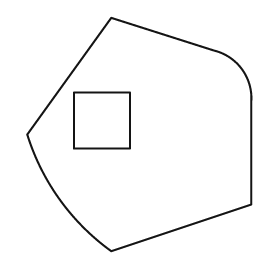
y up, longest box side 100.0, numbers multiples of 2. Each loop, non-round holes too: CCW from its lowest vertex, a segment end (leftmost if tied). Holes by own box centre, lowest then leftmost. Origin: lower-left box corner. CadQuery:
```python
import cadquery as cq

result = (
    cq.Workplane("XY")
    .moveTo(36.0, 0.0)
    .lineTo(96.0, 20.0)
    .lineTo(96.0, 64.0)
    .threePointArc((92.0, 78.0), (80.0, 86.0))
    .lineTo(36.0, 100.0)
    .lineTo(0.0, 50.0)
    .threePointArc((14.0, 22.0), (36.0, 0.0))
    .close()
    .moveTo(20.0, 44.0)
    .lineTo(44.0, 44.0)
    .lineTo(44.0, 68.0)
    .lineTo(20.0, 68.0)
    .close()
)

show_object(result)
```